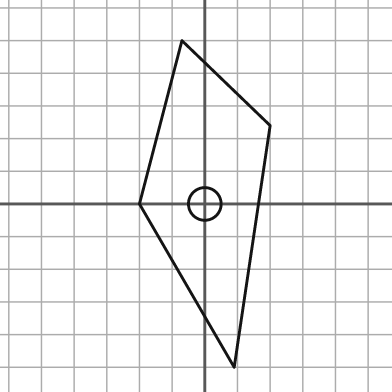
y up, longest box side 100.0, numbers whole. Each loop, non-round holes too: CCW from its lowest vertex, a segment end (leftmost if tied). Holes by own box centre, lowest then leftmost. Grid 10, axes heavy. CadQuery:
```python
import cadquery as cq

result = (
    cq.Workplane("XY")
    .moveTo(9.0, -50.0)
    .lineTo(20.0, 24.0)
    .lineTo(-7.0, 50.0)
    .lineTo(-20.0, 0.0)
    .close()
    .moveTo(0.0, 0.0)
    .circle(5.0)
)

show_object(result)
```